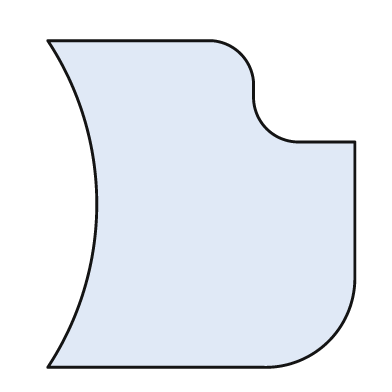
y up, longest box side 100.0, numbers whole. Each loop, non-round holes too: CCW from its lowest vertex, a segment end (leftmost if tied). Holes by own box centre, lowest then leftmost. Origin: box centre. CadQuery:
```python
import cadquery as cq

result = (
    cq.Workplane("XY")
    .moveTo(-47.0, -50.0)
    .lineTo(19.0, -50.0)
    .threePointArc((39.0, -42.0), (47.0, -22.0))
    .lineTo(47.0, 19.0)
    .lineTo(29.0, 19.0)
    .threePointArc((20.0, 23.0), (16.0, 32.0))
    .lineTo(16.0, 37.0)
    .threePointArc((12.0, 46.0), (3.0, 50.0))
    .lineTo(-47.0, 50.0)
    .threePointArc((-32.0, 0.0), (-47.0, -50.0))
    .close()
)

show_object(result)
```